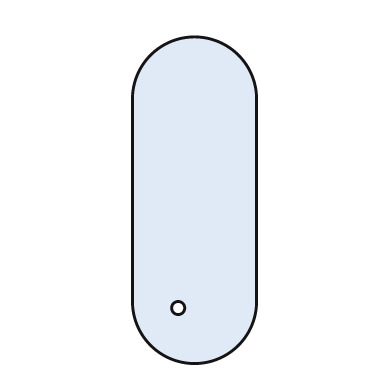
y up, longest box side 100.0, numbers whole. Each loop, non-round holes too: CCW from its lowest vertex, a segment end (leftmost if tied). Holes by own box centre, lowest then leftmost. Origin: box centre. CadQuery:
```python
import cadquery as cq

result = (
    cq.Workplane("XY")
    .moveTo(-19.0, -31.0)
    .threePointArc((0.0, -50.0), (19.0, -31.0))
    .lineTo(19.0, 31.0)
    .threePointArc((0.0, 50.0), (-19.0, 31.0))
    .close()
    .moveTo(-5.0, -33.0)
    .circle(2.0)
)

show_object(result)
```